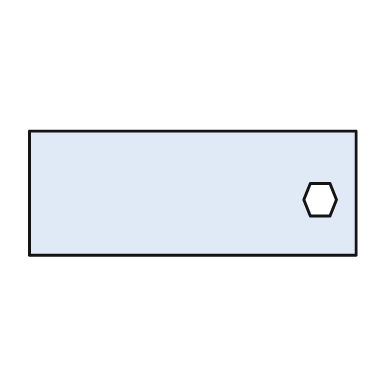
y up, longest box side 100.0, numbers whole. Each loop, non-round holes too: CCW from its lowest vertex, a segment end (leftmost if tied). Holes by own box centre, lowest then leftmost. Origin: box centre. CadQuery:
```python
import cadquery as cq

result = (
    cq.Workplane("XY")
    .moveTo(-50.0, -19.0)
    .lineTo(50.0, -19.0)
    .lineTo(50.0, 19.0)
    .lineTo(-50.0, 19.0)
    .close()
    .moveTo(36.0, -7.0)
    .lineTo(42.0, -7.0)
    .lineTo(44.0, -2.0)
    .lineTo(42.0, 3.0)
    .lineTo(36.0, 3.0)
    .lineTo(34.0, -2.0)
    .close()
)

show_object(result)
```